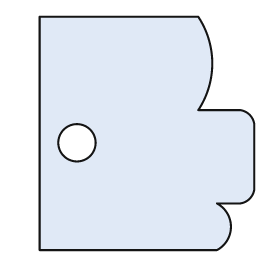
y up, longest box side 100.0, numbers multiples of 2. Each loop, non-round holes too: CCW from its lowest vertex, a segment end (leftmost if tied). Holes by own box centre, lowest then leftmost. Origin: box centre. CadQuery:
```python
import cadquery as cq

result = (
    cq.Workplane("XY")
    .moveTo(-46.0, -50.0)
    .lineTo(30.0, -50.0)
    .threePointArc((36.0, -40.0), (30.0, -30.0))
    .lineTo(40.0, -30.0)
    .threePointArc((44.0, -28.0), (46.0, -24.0))
    .lineTo(46.0, 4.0)
    .threePointArc((44.0, 8.0), (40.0, 10.0))
    .lineTo(22.0, 10.0)
    .threePointArc((28.0, 30.0), (22.0, 50.0))
    .lineTo(-46.0, 50.0)
    .close()
    .moveTo(-30.0, -4.0)
    .circle(8.0)
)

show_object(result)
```